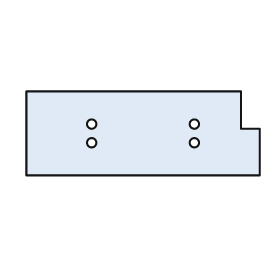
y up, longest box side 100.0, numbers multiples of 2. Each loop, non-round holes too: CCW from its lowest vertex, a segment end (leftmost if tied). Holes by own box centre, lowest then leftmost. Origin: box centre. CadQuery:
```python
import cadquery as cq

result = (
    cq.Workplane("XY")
    .moveTo(-50.0, -18.0)
    .lineTo(50.0, -18.0)
    .lineTo(50.0, 2.0)
    .lineTo(42.0, 2.0)
    .lineTo(42.0, 18.0)
    .lineTo(-50.0, 18.0)
    .close()
    .moveTo(-22.0, -4.0)
    .circle(2.0)
    .moveTo(22.0, -4.0)
    .circle(2.0)
    .moveTo(-22.0, 4.0)
    .circle(2.0)
    .moveTo(22.0, 4.0)
    .circle(2.0)
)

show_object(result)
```